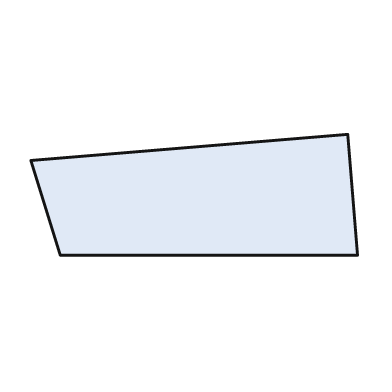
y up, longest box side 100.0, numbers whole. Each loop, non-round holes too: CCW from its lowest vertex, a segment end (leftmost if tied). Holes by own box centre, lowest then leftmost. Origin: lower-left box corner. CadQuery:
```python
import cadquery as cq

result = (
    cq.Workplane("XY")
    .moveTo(9.0, 0.0)
    .lineTo(100.0, 0.0)
    .lineTo(97.0, 37.0)
    .lineTo(0.0, 29.0)
    .close()
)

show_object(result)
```